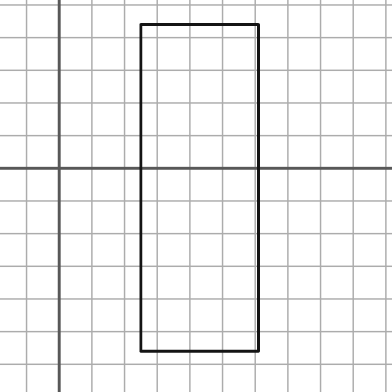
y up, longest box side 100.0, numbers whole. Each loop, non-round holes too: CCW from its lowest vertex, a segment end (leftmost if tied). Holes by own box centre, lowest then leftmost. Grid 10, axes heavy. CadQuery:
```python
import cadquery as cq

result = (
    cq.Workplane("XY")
    .moveTo(25.0, -56.0)
    .lineTo(61.0, -56.0)
    .lineTo(61.0, 44.0)
    .lineTo(25.0, 44.0)
    .close()
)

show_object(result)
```